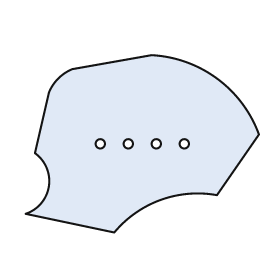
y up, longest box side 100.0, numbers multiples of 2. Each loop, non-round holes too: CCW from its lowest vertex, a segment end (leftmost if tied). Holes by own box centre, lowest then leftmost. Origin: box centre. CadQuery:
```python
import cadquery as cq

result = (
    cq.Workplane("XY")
    .moveTo(-12.0, -38.0)
    .threePointArc((8.0, -24.0), (32.0, -22.0))
    .lineTo(50.0, 4.0)
    .threePointArc((32.0, 28.0), (4.0, 38.0))
    .lineTo(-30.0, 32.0)
    .threePointArc((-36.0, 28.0), (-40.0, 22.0))
    .lineTo(-46.0, -4.0)
    .threePointArc((-40.0, -18.0), (-50.0, -30.0))
    .close()
    .moveTo(-18.0, 0.0)
    .circle(2.0)
    .moveTo(-6.0, 0.0)
    .circle(2.0)
    .moveTo(6.0, 0.0)
    .circle(2.0)
    .moveTo(18.0, 0.0)
    .circle(2.0)
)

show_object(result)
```